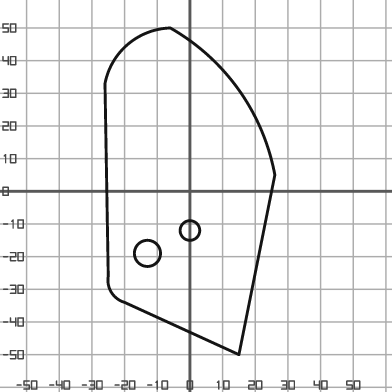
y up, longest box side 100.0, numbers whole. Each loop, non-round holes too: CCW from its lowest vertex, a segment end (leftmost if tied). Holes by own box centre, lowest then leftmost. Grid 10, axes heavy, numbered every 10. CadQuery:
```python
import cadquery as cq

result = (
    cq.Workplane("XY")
    .moveTo(15.0, -50.0)
    .lineTo(26.0, 5.0)
    .threePointArc((15.0, 31.0), (-6.0, 50.0))
    .threePointArc((-19.0, 45.0), (-26.0, 33.0))
    .lineTo(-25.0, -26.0)
    .threePointArc((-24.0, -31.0), (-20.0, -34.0))
    .close()
    .moveTo(-13.0, -19.0)
    .circle(4.0)
    .moveTo(0.0, -12.0)
    .circle(3.0)
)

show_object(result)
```